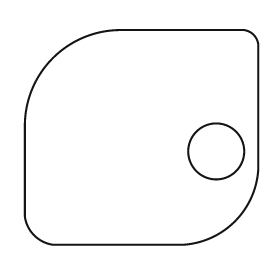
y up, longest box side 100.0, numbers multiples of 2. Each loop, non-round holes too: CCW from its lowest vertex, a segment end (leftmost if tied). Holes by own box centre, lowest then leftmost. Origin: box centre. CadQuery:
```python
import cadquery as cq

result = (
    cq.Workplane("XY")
    .moveTo(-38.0, -46.0)
    .lineTo(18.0, -46.0)
    .threePointArc((40.0, -36.0), (50.0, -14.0))
    .lineTo(50.0, 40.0)
    .threePointArc((48.0, 44.0), (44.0, 46.0))
    .lineTo(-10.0, 46.0)
    .threePointArc((-38.0, 34.0), (-50.0, 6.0))
    .lineTo(-50.0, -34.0)
    .threePointArc((-46.0, -42.0), (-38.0, -46.0))
    .close()
    .moveTo(32.0, -6.0)
    .circle(12.0)
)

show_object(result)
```